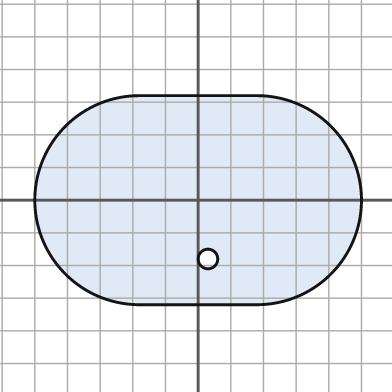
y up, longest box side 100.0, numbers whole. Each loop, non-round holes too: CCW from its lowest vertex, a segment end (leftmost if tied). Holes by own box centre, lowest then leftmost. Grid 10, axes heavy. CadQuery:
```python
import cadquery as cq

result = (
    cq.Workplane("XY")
    .moveTo(-18.0, -32.0)
    .lineTo(18.0, -32.0)
    .threePointArc((50.0, 0.0), (18.0, 32.0))
    .lineTo(-18.0, 32.0)
    .threePointArc((-50.0, 0.0), (-18.0, -32.0))
    .close()
    .moveTo(3.0, -18.0)
    .circle(3.0)
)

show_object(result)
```